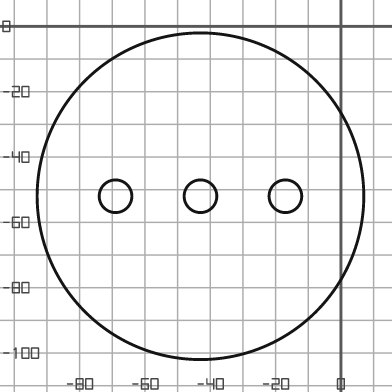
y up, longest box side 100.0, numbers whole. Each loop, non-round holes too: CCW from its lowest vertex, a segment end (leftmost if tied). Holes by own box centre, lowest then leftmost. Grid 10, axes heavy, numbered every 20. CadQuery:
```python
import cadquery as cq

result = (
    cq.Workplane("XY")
    .moveTo(-43.0, -52.0)
    .circle(50.0)
    .moveTo(-69.0, -52.0)
    .circle(5.0)
    .moveTo(-43.0, -52.0)
    .circle(5.0)
    .moveTo(-17.0, -52.0)
    .circle(5.0)
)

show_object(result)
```